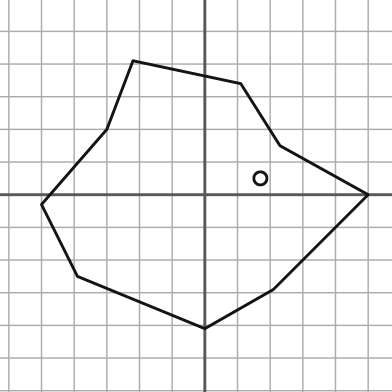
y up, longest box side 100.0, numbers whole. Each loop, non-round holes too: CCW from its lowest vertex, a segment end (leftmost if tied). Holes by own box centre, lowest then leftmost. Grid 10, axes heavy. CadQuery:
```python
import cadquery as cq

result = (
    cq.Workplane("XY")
    .moveTo(0.0, -41.0)
    .lineTo(21.0, -29.0)
    .lineTo(50.0, 0.0)
    .lineTo(23.0, 15.0)
    .lineTo(11.0, 34.0)
    .lineTo(-22.0, 41.0)
    .lineTo(-30.0, 20.0)
    .lineTo(-50.0, -3.0)
    .lineTo(-39.0, -25.0)
    .close()
    .moveTo(17.0, 5.0)
    .circle(2.0)
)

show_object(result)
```